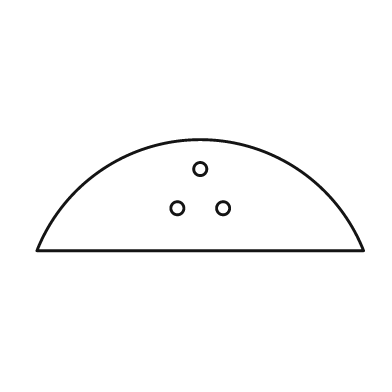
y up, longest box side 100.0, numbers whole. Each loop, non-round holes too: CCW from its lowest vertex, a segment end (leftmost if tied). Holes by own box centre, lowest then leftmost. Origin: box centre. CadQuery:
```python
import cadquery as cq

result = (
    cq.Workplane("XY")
    .moveTo(-50.0, -17.0)
    .lineTo(50.0, -17.0)
    .threePointArc((0.0, 17.0), (-50.0, -17.0))
    .close()
    .moveTo(-7.0, -4.0)
    .circle(2.0)
    .moveTo(7.0, -4.0)
    .circle(2.0)
    .moveTo(0.0, 8.0)
    .circle(2.0)
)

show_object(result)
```